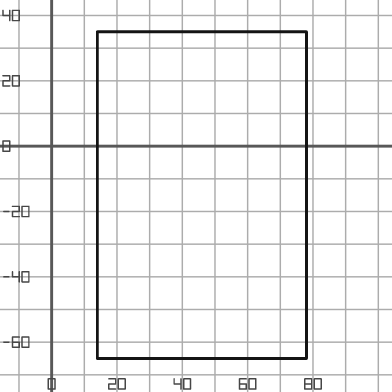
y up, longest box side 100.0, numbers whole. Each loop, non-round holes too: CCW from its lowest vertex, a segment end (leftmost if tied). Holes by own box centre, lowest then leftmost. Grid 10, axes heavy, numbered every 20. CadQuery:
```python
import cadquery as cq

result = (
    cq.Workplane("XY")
    .moveTo(14.0, -65.0)
    .lineTo(78.0, -65.0)
    .lineTo(78.0, 35.0)
    .lineTo(14.0, 35.0)
    .close()
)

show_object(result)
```